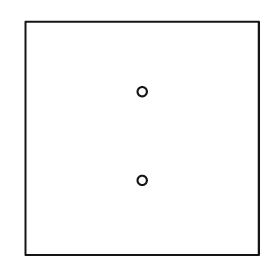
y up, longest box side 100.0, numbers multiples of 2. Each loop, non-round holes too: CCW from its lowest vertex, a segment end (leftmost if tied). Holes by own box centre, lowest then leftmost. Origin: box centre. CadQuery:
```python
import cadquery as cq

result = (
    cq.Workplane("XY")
    .moveTo(-50.0, -50.0)
    .lineTo(50.0, -50.0)
    .lineTo(50.0, 50.0)
    .lineTo(-50.0, 50.0)
    .close()
    .moveTo(0.0, -18.0)
    .circle(2.0)
    .moveTo(0.0, 20.0)
    .circle(2.0)
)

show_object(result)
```